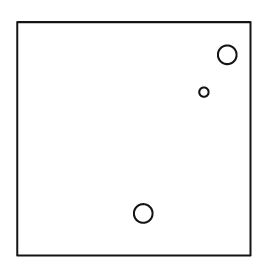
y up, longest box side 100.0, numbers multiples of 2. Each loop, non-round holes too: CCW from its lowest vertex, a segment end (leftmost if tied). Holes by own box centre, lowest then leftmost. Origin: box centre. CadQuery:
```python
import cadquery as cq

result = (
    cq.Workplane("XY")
    .moveTo(-50.0, -50.0)
    .lineTo(50.0, -50.0)
    .lineTo(50.0, 50.0)
    .lineTo(-50.0, 50.0)
    .close()
    .moveTo(4.0, -32.0)
    .circle(4.0)
    .moveTo(30.0, 20.0)
    .circle(2.0)
    .moveTo(40.0, 36.0)
    .circle(4.0)
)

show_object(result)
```